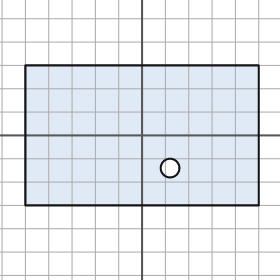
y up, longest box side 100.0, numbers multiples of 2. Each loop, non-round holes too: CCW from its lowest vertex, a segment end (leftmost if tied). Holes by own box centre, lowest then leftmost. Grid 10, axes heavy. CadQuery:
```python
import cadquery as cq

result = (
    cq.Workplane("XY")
    .moveTo(-50.0, -30.0)
    .lineTo(50.0, -30.0)
    .lineTo(50.0, 30.0)
    .lineTo(-50.0, 30.0)
    .close()
    .moveTo(12.0, -14.0)
    .circle(4.0)
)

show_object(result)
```